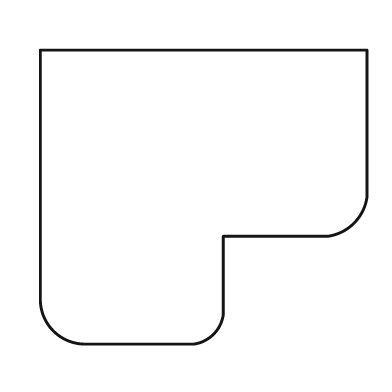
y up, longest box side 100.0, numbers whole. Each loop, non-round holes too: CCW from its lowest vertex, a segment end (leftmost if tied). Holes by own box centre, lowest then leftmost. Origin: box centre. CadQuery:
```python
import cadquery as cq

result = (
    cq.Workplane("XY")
    .moveTo(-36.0, -45.0)
    .lineTo(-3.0, -45.0)
    .threePointArc((3.0, -42.0), (6.0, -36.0))
    .lineTo(6.0, -12.0)
    .lineTo(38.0, -12.0)
    .threePointArc((46.0, -8.0), (50.0, 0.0))
    .lineTo(50.0, 45.0)
    .lineTo(-50.0, 45.0)
    .lineTo(-50.0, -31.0)
    .threePointArc((-46.0, -41.0), (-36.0, -45.0))
    .close()
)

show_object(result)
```